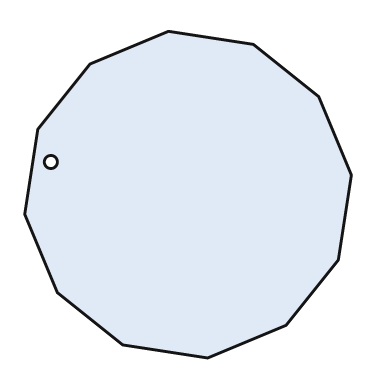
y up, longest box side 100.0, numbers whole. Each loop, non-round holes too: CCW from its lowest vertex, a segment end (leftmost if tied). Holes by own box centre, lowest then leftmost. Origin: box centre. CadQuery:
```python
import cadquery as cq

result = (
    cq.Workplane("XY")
    .moveTo(6.0, -50.0)
    .lineTo(30.0, -40.0)
    .lineTo(46.0, -20.0)
    .lineTo(50.0, 6.0)
    .lineTo(40.0, 30.0)
    .lineTo(20.0, 46.0)
    .lineTo(-6.0, 50.0)
    .lineTo(-30.0, 40.0)
    .lineTo(-46.0, 20.0)
    .lineTo(-50.0, -6.0)
    .lineTo(-40.0, -30.0)
    .lineTo(-20.0, -46.0)
    .close()
    .moveTo(-42.0, 10.0)
    .circle(2.0)
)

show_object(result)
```